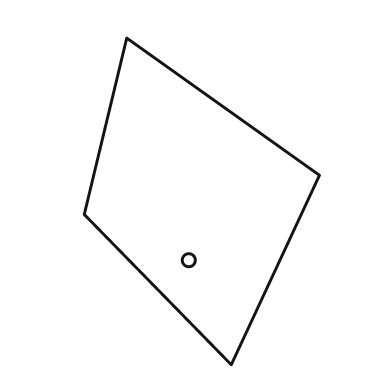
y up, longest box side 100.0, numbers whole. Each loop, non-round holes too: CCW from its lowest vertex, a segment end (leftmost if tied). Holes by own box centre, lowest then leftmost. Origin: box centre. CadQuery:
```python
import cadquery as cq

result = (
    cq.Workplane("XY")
    .moveTo(9.0, -50.0)
    .lineTo(36.0, 8.0)
    .lineTo(-23.0, 50.0)
    .lineTo(-36.0, -4.0)
    .close()
    .moveTo(-4.0, -18.0)
    .circle(2.0)
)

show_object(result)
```